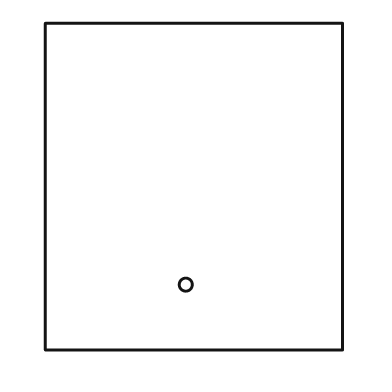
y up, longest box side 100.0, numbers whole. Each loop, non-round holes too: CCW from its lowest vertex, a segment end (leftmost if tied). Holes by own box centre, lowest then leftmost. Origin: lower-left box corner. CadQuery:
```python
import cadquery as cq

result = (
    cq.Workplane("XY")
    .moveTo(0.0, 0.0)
    .lineTo(91.0, 0.0)
    .lineTo(91.0, 100.0)
    .lineTo(0.0, 100.0)
    .close()
    .moveTo(43.0, 20.0)
    .circle(2.0)
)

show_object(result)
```